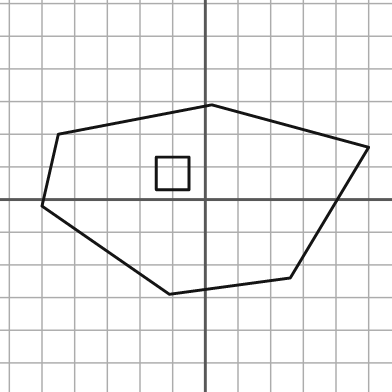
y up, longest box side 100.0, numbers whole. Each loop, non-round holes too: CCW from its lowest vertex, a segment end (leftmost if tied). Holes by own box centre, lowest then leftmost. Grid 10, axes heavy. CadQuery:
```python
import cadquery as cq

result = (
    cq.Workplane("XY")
    .moveTo(-11.0, -29.0)
    .lineTo(26.0, -24.0)
    .lineTo(50.0, 16.0)
    .lineTo(2.0, 29.0)
    .lineTo(-45.0, 20.0)
    .lineTo(-50.0, -2.0)
    .close()
    .moveTo(-15.0, 3.0)
    .lineTo(-5.0, 3.0)
    .lineTo(-5.0, 13.0)
    .lineTo(-15.0, 13.0)
    .close()
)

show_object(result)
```